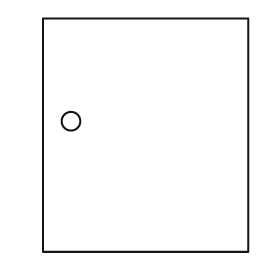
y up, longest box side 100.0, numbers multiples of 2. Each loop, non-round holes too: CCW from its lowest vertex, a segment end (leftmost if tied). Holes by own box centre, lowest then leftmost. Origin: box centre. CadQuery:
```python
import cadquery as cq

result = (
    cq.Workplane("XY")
    .moveTo(-44.0, -50.0)
    .lineTo(44.0, -50.0)
    .lineTo(44.0, 50.0)
    .lineTo(-44.0, 50.0)
    .close()
    .moveTo(-32.0, 6.0)
    .circle(4.0)
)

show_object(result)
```